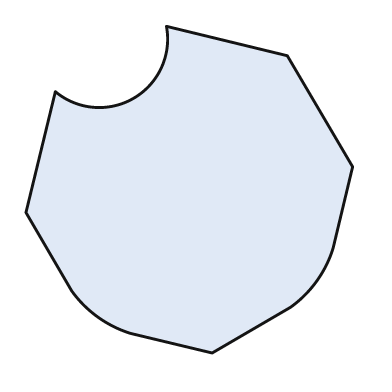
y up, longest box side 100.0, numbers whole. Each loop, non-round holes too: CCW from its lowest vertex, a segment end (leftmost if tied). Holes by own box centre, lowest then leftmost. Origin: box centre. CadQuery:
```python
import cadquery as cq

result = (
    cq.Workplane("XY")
    .moveTo(7.0, -50.0)
    .lineTo(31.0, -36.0)
    .threePointArc((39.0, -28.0), (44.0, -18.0))
    .lineTo(50.0, 7.0)
    .lineTo(30.0, 41.0)
    .lineTo(-7.0, 50.0)
    .threePointArc((-17.0, 28.0), (-41.0, 30.0))
    .lineTo(-50.0, -7.0)
    .lineTo(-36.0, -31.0)
    .threePointArc((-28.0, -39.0), (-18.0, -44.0))
    .close()
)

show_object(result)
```